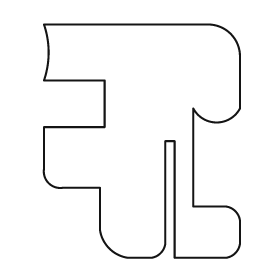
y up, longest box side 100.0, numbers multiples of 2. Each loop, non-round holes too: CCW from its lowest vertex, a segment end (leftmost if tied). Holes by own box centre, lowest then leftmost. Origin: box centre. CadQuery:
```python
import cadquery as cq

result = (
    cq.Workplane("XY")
    .moveTo(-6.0, -50.0)
    .lineTo(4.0, -50.0)
    .threePointArc((8.0, -48.0), (10.0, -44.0))
    .lineTo(10.0, 0.0)
    .lineTo(14.0, 0.0)
    .lineTo(14.0, -50.0)
    .lineTo(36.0, -50.0)
    .threePointArc((40.0, -48.0), (42.0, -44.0))
    .lineTo(42.0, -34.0)
    .threePointArc((40.0, -30.0), (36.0, -28.0))
    .lineTo(22.0, -28.0)
    .lineTo(22.0, 14.0)
    .threePointArc((32.0, 8.0), (42.0, 14.0))
    .lineTo(42.0, 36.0)
    .threePointArc((38.0, 46.0), (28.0, 50.0))
    .lineTo(-42.0, 50.0)
    .threePointArc((-40.0, 38.0), (-42.0, 26.0))
    .lineTo(-16.0, 26.0)
    .lineTo(-16.0, 6.0)
    .lineTo(-42.0, 6.0)
    .lineTo(-42.0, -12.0)
    .threePointArc((-40.0, -18.0), (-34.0, -20.0))
    .lineTo(-18.0, -20.0)
    .lineTo(-18.0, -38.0)
    .threePointArc((-14.0, -46.0), (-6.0, -50.0))
    .close()
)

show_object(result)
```